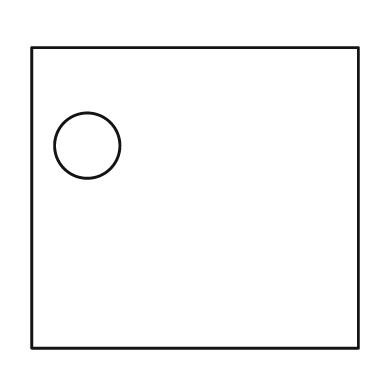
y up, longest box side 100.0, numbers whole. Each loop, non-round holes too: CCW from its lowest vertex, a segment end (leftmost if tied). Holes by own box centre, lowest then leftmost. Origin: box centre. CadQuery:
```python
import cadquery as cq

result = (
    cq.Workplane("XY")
    .moveTo(-50.0, -46.0)
    .lineTo(50.0, -46.0)
    .lineTo(50.0, 46.0)
    .lineTo(-50.0, 46.0)
    .close()
    .moveTo(-33.0, 16.0)
    .circle(10.0)
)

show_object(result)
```